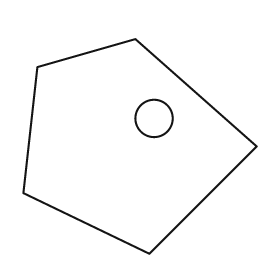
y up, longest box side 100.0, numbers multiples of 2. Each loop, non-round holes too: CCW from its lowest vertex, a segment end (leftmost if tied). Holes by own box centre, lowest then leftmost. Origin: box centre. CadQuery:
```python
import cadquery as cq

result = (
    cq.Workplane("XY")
    .moveTo(4.0, -46.0)
    .lineTo(50.0, 0.0)
    .lineTo(-2.0, 46.0)
    .lineTo(-44.0, 34.0)
    .lineTo(-50.0, -20.0)
    .close()
    .moveTo(6.0, 12.0)
    .circle(8.0)
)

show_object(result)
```